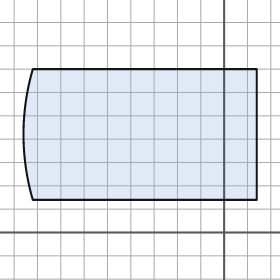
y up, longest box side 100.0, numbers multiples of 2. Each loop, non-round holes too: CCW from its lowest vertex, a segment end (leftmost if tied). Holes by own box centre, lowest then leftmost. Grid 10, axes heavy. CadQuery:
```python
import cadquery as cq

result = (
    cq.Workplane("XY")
    .moveTo(-82.0, 14.0)
    .lineTo(14.0, 14.0)
    .lineTo(14.0, 70.0)
    .lineTo(-82.0, 70.0)
    .threePointArc((-86.0, 42.0), (-82.0, 14.0))
    .close()
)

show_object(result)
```